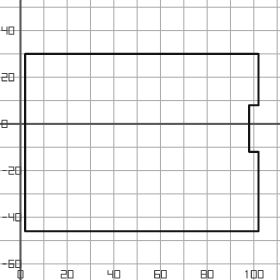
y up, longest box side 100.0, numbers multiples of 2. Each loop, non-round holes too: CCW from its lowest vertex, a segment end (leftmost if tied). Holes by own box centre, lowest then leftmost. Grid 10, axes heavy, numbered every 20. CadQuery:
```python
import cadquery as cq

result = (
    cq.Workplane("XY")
    .moveTo(2.0, -46.0)
    .lineTo(102.0, -46.0)
    .lineTo(102.0, -12.0)
    .lineTo(98.0, -12.0)
    .lineTo(98.0, 8.0)
    .lineTo(102.0, 8.0)
    .lineTo(102.0, 30.0)
    .lineTo(2.0, 30.0)
    .close()
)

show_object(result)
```